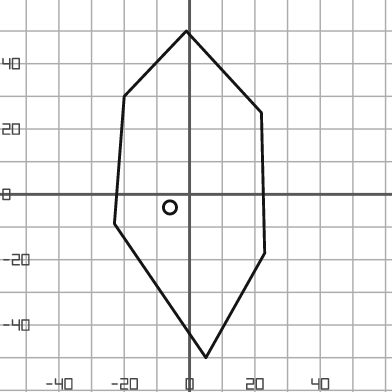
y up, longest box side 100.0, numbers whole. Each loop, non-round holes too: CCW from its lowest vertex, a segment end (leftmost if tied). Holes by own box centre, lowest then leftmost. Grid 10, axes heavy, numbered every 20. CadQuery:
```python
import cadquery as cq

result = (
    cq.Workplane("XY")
    .moveTo(5.0, -50.0)
    .lineTo(23.0, -18.0)
    .lineTo(22.0, 25.0)
    .lineTo(-1.0, 50.0)
    .lineTo(-20.0, 30.0)
    .lineTo(-23.0, -9.0)
    .close()
    .moveTo(-6.0, -4.0)
    .circle(2.0)
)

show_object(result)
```